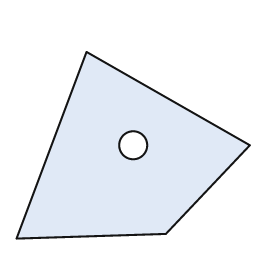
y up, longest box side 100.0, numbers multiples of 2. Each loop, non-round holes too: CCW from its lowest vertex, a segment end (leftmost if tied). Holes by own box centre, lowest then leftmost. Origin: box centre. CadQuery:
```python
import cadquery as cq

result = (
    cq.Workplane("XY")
    .moveTo(-50.0, -40.0)
    .lineTo(14.0, -38.0)
    .lineTo(50.0, 0.0)
    .lineTo(-20.0, 40.0)
    .close()
    .moveTo(0.0, 0.0)
    .circle(6.0)
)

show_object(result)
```